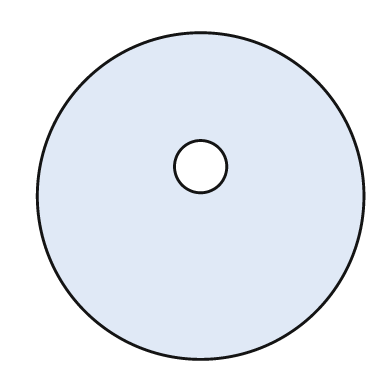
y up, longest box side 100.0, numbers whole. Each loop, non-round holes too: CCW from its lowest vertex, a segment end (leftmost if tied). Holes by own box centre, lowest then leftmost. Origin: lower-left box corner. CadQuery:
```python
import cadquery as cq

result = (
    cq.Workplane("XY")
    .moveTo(50.0, 50.0)
    .circle(50.0)
    .moveTo(50.0, 59.0)
    .circle(8.0)
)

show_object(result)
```